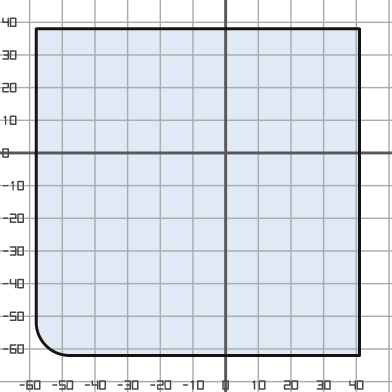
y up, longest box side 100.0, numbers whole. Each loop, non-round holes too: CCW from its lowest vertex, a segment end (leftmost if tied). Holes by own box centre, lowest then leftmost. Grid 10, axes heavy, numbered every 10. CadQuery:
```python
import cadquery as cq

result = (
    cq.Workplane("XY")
    .moveTo(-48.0, -62.0)
    .lineTo(41.0, -62.0)
    .lineTo(41.0, 38.0)
    .lineTo(-58.0, 38.0)
    .lineTo(-58.0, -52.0)
    .threePointArc((-55.0, -59.0), (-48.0, -62.0))
    .close()
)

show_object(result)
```